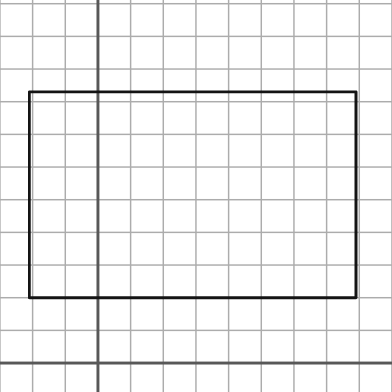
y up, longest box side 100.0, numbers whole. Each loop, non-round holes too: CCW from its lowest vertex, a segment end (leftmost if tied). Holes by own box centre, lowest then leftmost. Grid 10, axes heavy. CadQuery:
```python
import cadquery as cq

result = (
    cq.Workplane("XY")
    .moveTo(-21.0, 20.0)
    .lineTo(79.0, 20.0)
    .lineTo(79.0, 83.0)
    .lineTo(-21.0, 83.0)
    .close()
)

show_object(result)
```